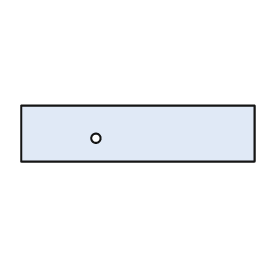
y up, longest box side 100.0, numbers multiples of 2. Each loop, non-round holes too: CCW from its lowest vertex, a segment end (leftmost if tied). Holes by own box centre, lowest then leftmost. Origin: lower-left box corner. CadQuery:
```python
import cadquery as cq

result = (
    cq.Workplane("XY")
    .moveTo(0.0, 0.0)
    .lineTo(100.0, 0.0)
    .lineTo(100.0, 24.0)
    .lineTo(0.0, 24.0)
    .close()
    .moveTo(32.0, 10.0)
    .circle(2.0)
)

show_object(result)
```